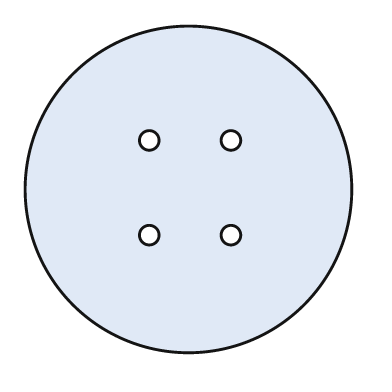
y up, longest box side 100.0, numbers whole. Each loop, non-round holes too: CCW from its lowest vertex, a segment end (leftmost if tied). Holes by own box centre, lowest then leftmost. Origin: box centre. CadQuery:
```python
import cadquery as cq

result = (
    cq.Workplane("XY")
    .moveTo(0.0, 0.0)
    .circle(50.0)
    .moveTo(-12.0, -14.0)
    .circle(3.0)
    .moveTo(13.0, -14.0)
    .circle(3.0)
    .moveTo(-12.0, 15.0)
    .circle(3.0)
    .moveTo(13.0, 15.0)
    .circle(3.0)
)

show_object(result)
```